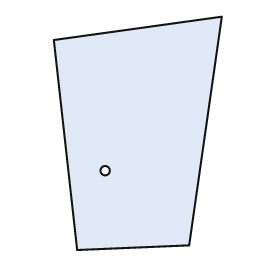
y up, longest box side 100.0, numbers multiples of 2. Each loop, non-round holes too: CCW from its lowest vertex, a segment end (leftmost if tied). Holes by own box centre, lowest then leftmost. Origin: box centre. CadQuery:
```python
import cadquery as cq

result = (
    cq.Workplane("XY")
    .moveTo(-26.0, -50.0)
    .lineTo(22.0, -48.0)
    .lineTo(36.0, 50.0)
    .lineTo(-36.0, 40.0)
    .close()
    .moveTo(-14.0, -16.0)
    .circle(2.0)
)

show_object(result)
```